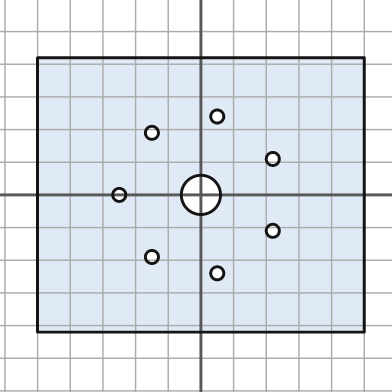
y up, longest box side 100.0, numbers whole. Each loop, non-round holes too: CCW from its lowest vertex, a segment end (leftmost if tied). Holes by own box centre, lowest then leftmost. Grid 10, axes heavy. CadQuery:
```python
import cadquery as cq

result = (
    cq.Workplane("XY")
    .moveTo(-50.0, -42.0)
    .lineTo(50.0, -42.0)
    .lineTo(50.0, 42.0)
    .lineTo(-50.0, 42.0)
    .close()
    .moveTo(5.0, -24.0)
    .circle(2.0)
    .moveTo(-15.0, -19.0)
    .circle(2.0)
    .moveTo(22.0, -11.0)
    .circle(2.0)
    .moveTo(-25.0, 0.0)
    .circle(2.0)
    .moveTo(0.0, 0.0)
    .circle(6.0)
    .moveTo(22.0, 11.0)
    .circle(2.0)
    .moveTo(-15.0, 19.0)
    .circle(2.0)
    .moveTo(5.0, 24.0)
    .circle(2.0)
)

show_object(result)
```